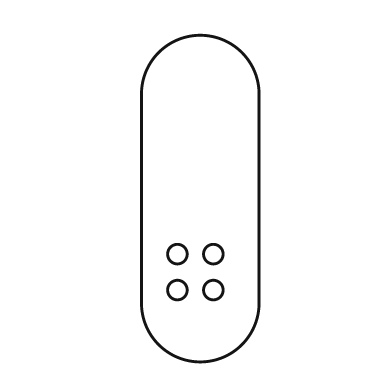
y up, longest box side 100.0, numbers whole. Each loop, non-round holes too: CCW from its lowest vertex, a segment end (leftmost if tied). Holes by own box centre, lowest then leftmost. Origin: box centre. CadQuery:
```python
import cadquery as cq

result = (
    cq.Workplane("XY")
    .moveTo(-18.0, -32.0)
    .threePointArc((0.0, -50.0), (18.0, -32.0))
    .lineTo(18.0, 32.0)
    .threePointArc((0.0, 50.0), (-18.0, 32.0))
    .close()
    .moveTo(-7.0, -28.0)
    .circle(3.0)
    .moveTo(4.0, -28.0)
    .circle(3.0)
    .moveTo(-7.0, -17.0)
    .circle(3.0)
    .moveTo(4.0, -17.0)
    .circle(3.0)
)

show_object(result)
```